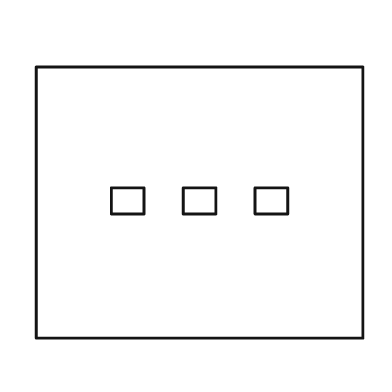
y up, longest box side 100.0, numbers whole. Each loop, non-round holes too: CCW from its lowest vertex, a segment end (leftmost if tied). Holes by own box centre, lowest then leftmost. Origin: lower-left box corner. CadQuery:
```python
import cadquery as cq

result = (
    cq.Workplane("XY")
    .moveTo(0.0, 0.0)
    .lineTo(100.0, 0.0)
    .lineTo(100.0, 83.0)
    .lineTo(0.0, 83.0)
    .close()
    .moveTo(23.0, 38.0)
    .lineTo(33.0, 38.0)
    .lineTo(33.0, 46.0)
    .lineTo(23.0, 46.0)
    .close()
    .moveTo(45.0, 38.0)
    .lineTo(55.0, 38.0)
    .lineTo(55.0, 46.0)
    .lineTo(45.0, 46.0)
    .close()
    .moveTo(67.0, 38.0)
    .lineTo(77.0, 38.0)
    .lineTo(77.0, 46.0)
    .lineTo(67.0, 46.0)
    .close()
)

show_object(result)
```